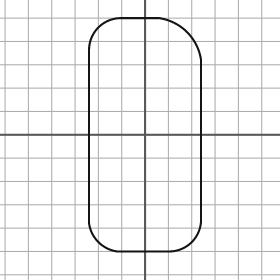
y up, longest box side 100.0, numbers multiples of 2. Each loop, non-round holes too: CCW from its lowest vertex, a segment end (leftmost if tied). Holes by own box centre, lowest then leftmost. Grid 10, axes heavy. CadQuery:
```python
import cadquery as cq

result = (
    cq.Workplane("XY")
    .moveTo(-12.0, -50.0)
    .lineTo(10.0, -50.0)
    .threePointArc((20.0, -46.0), (24.0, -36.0))
    .lineTo(24.0, 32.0)
    .threePointArc((18.0, 44.0), (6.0, 50.0))
    .lineTo(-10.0, 50.0)
    .threePointArc((-20.0, 46.0), (-24.0, 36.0))
    .lineTo(-24.0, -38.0)
    .threePointArc((-20.0, -46.0), (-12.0, -50.0))
    .close()
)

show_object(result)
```